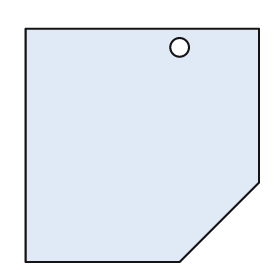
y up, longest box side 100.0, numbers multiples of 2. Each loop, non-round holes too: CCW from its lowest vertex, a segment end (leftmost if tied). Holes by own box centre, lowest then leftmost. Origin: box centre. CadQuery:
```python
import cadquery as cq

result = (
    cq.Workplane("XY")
    .moveTo(-50.0, -50.0)
    .lineTo(16.0, -50.0)
    .lineTo(50.0, -16.0)
    .lineTo(50.0, 50.0)
    .lineTo(-50.0, 50.0)
    .close()
    .moveTo(16.0, 42.0)
    .circle(4.0)
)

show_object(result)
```